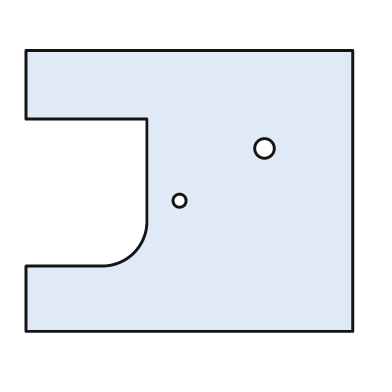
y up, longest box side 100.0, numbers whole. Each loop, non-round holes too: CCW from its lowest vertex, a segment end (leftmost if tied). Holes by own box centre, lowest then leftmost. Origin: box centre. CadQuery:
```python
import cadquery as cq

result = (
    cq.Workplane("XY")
    .moveTo(-50.0, -43.0)
    .lineTo(50.0, -43.0)
    .lineTo(50.0, 43.0)
    .lineTo(-50.0, 43.0)
    .lineTo(-50.0, 22.0)
    .lineTo(-13.0, 22.0)
    .lineTo(-13.0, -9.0)
    .threePointArc((-17.0, -19.0), (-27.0, -23.0))
    .lineTo(-50.0, -23.0)
    .close()
    .moveTo(-3.0, -3.0)
    .circle(2.0)
    .moveTo(23.0, 13.0)
    .circle(3.0)
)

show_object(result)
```